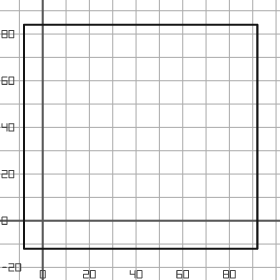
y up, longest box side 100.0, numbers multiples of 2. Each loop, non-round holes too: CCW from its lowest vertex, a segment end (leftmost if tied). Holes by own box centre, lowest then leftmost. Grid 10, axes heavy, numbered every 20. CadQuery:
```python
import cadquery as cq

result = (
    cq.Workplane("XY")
    .moveTo(-8.0, -12.0)
    .lineTo(92.0, -12.0)
    .lineTo(92.0, 84.0)
    .lineTo(-8.0, 84.0)
    .close()
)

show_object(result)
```